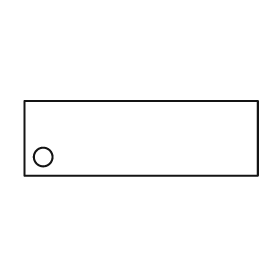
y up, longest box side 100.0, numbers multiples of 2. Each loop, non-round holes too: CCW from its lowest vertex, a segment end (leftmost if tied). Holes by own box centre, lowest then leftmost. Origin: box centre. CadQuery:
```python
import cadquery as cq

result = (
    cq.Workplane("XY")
    .moveTo(-50.0, -16.0)
    .lineTo(50.0, -16.0)
    .lineTo(50.0, 16.0)
    .lineTo(-50.0, 16.0)
    .close()
    .moveTo(-42.0, -8.0)
    .circle(4.0)
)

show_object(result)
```